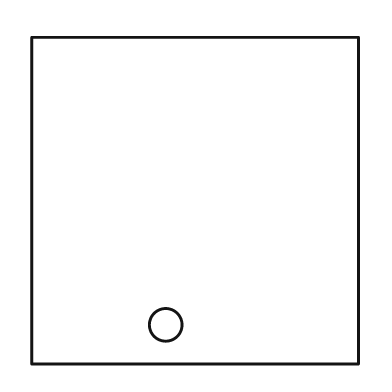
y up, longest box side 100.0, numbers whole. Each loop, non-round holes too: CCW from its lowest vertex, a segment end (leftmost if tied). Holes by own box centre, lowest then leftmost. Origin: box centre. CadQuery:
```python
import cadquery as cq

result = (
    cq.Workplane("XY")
    .moveTo(-50.0, -50.0)
    .lineTo(50.0, -50.0)
    .lineTo(50.0, 50.0)
    .lineTo(-50.0, 50.0)
    .close()
    .moveTo(-9.0, -38.0)
    .circle(5.0)
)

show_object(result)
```